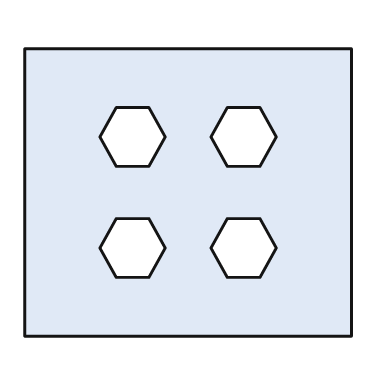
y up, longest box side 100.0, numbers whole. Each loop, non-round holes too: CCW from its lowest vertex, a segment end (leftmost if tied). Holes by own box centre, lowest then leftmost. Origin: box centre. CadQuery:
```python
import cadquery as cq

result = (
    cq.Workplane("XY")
    .moveTo(-50.0, -44.0)
    .lineTo(50.0, -44.0)
    .lineTo(50.0, 44.0)
    .lineTo(-50.0, 44.0)
    .close()
    .moveTo(-22.0, -26.0)
    .lineTo(-12.0, -26.0)
    .lineTo(-7.0, -17.0)
    .lineTo(-12.0, -8.0)
    .lineTo(-22.0, -8.0)
    .lineTo(-27.0, -17.0)
    .close()
    .moveTo(12.0, -26.0)
    .lineTo(22.0, -26.0)
    .lineTo(27.0, -17.0)
    .lineTo(22.0, -8.0)
    .lineTo(12.0, -8.0)
    .lineTo(7.0, -17.0)
    .close()
    .moveTo(-22.0, 8.0)
    .lineTo(-12.0, 8.0)
    .lineTo(-7.0, 17.0)
    .lineTo(-12.0, 26.0)
    .lineTo(-22.0, 26.0)
    .lineTo(-27.0, 17.0)
    .close()
    .moveTo(12.0, 8.0)
    .lineTo(22.0, 8.0)
    .lineTo(27.0, 17.0)
    .lineTo(22.0, 26.0)
    .lineTo(12.0, 26.0)
    .lineTo(7.0, 17.0)
    .close()
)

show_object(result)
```